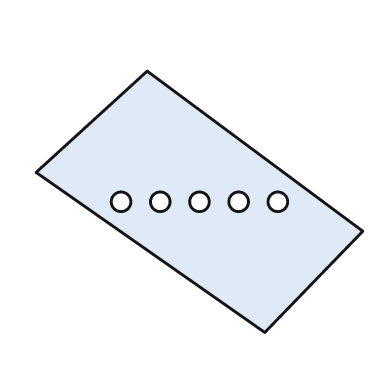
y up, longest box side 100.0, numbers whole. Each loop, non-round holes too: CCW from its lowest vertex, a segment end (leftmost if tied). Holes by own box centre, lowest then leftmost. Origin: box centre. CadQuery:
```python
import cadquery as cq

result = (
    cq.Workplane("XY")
    .moveTo(20.0, -40.0)
    .lineTo(50.0, -9.0)
    .lineTo(-16.0, 40.0)
    .lineTo(-50.0, 9.0)
    .close()
    .moveTo(-24.0, 0.0)
    .circle(3.0)
    .moveTo(-12.0, 0.0)
    .circle(3.0)
    .moveTo(0.0, 0.0)
    .circle(3.0)
    .moveTo(12.0, 0.0)
    .circle(3.0)
    .moveTo(24.0, 0.0)
    .circle(3.0)
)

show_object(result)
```